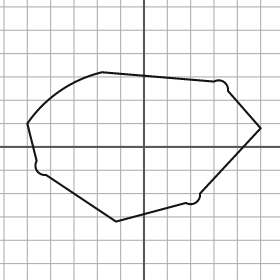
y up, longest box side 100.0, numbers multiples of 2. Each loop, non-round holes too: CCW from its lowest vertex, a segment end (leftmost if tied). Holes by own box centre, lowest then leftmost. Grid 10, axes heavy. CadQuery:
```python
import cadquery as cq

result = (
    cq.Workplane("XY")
    .moveTo(-12.0, -32.0)
    .lineTo(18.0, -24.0)
    .threePointArc((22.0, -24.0), (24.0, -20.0))
    .lineTo(50.0, 8.0)
    .lineTo(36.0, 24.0)
    .threePointArc((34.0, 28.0), (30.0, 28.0))
    .lineTo(-18.0, 32.0)
    .threePointArc((-36.0, 24.0), (-50.0, 10.0))
    .lineTo(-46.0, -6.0)
    .threePointArc((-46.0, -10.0), (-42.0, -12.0))
    .close()
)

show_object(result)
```